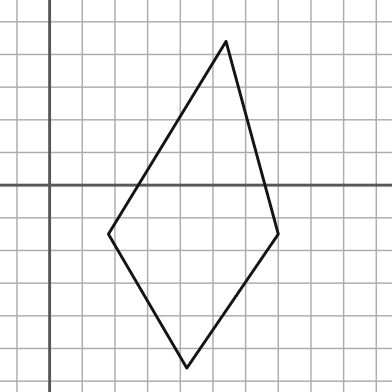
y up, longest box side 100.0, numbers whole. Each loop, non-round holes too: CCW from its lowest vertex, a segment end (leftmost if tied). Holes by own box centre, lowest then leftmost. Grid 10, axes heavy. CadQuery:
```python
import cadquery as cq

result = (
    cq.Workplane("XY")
    .moveTo(42.0, -56.0)
    .lineTo(70.0, -15.0)
    .lineTo(54.0, 44.0)
    .lineTo(18.0, -15.0)
    .close()
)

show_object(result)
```